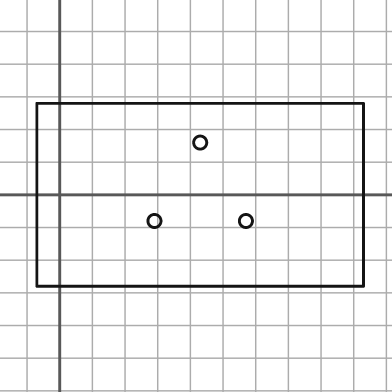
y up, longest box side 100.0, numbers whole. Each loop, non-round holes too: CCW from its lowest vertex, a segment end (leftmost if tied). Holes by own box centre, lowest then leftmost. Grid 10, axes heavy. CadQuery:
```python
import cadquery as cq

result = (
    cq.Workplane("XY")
    .moveTo(-7.0, -28.0)
    .lineTo(93.0, -28.0)
    .lineTo(93.0, 28.0)
    .lineTo(-7.0, 28.0)
    .close()
    .moveTo(29.0, -8.0)
    .circle(2.0)
    .moveTo(57.0, -8.0)
    .circle(2.0)
    .moveTo(43.0, 16.0)
    .circle(2.0)
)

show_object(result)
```